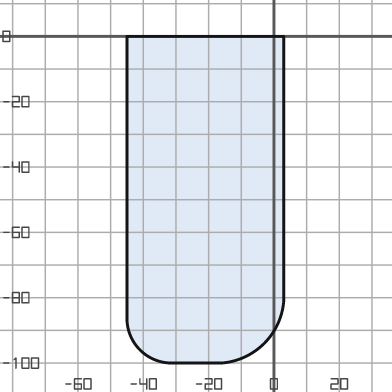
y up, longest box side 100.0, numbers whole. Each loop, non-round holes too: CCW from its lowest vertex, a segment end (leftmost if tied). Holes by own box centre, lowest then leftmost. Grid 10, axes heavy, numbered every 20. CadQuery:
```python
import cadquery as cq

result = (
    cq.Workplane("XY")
    .moveTo(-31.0, -100.0)
    .lineTo(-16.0, -100.0)
    .threePointArc((-3.0, -94.0), (3.0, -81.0))
    .lineTo(3.0, 0.0)
    .lineTo(-45.0, 0.0)
    .lineTo(-45.0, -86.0)
    .threePointArc((-41.0, -96.0), (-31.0, -100.0))
    .close()
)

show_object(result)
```